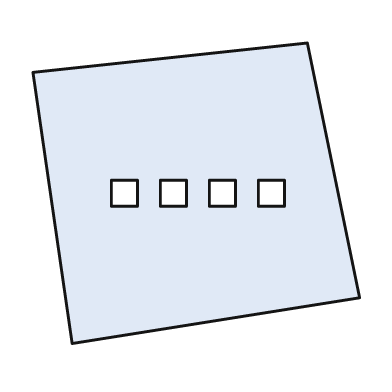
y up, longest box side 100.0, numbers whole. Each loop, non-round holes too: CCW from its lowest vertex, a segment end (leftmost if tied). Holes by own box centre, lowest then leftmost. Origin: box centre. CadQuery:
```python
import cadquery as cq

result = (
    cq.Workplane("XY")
    .moveTo(-38.0, -46.0)
    .lineTo(50.0, -32.0)
    .lineTo(34.0, 46.0)
    .lineTo(-50.0, 37.0)
    .close()
    .moveTo(-26.0, -4.0)
    .lineTo(-18.0, -4.0)
    .lineTo(-18.0, 4.0)
    .lineTo(-26.0, 4.0)
    .close()
    .moveTo(-11.0, -4.0)
    .lineTo(-3.0, -4.0)
    .lineTo(-3.0, 4.0)
    .lineTo(-11.0, 4.0)
    .close()
    .moveTo(4.0, -4.0)
    .lineTo(12.0, -4.0)
    .lineTo(12.0, 4.0)
    .lineTo(4.0, 4.0)
    .close()
    .moveTo(19.0, -4.0)
    .lineTo(27.0, -4.0)
    .lineTo(27.0, 4.0)
    .lineTo(19.0, 4.0)
    .close()
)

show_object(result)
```